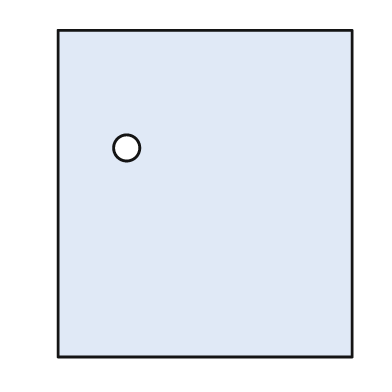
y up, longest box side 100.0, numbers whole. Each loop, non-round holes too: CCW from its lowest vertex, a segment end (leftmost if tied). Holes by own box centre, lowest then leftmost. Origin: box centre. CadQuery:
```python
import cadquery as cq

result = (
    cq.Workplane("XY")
    .moveTo(-45.0, -50.0)
    .lineTo(45.0, -50.0)
    .lineTo(45.0, 50.0)
    .lineTo(-45.0, 50.0)
    .close()
    .moveTo(-24.0, 14.0)
    .circle(4.0)
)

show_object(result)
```